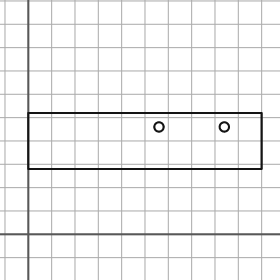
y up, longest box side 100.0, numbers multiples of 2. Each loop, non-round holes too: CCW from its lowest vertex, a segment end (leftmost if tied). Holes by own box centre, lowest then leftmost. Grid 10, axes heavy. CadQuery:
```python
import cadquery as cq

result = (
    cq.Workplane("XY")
    .moveTo(0.0, 28.0)
    .lineTo(100.0, 28.0)
    .lineTo(100.0, 52.0)
    .lineTo(0.0, 52.0)
    .close()
    .moveTo(56.0, 46.0)
    .circle(2.0)
    .moveTo(84.0, 46.0)
    .circle(2.0)
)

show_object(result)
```